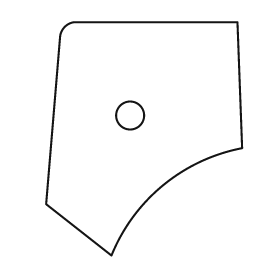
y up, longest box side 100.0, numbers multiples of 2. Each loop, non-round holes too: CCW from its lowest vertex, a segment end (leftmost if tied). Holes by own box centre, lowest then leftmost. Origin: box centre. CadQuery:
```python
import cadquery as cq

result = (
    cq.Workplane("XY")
    .moveTo(-14.0, -50.0)
    .threePointArc((8.0, -20.0), (42.0, -4.0))
    .lineTo(40.0, 50.0)
    .lineTo(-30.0, 50.0)
    .threePointArc((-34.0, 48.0), (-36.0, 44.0))
    .lineTo(-42.0, -28.0)
    .close()
    .moveTo(-6.0, 10.0)
    .circle(6.0)
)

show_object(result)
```